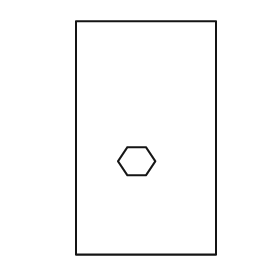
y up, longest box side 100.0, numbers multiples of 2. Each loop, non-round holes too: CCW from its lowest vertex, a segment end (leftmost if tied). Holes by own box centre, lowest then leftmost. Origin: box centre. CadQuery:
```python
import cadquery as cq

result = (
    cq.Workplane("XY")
    .moveTo(-30.0, -50.0)
    .lineTo(30.0, -50.0)
    .lineTo(30.0, 50.0)
    .lineTo(-30.0, 50.0)
    .close()
    .moveTo(-8.0, -16.0)
    .lineTo(0.0, -16.0)
    .lineTo(4.0, -10.0)
    .lineTo(0.0, -4.0)
    .lineTo(-8.0, -4.0)
    .lineTo(-12.0, -10.0)
    .close()
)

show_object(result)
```